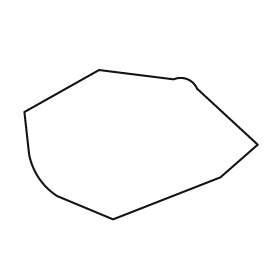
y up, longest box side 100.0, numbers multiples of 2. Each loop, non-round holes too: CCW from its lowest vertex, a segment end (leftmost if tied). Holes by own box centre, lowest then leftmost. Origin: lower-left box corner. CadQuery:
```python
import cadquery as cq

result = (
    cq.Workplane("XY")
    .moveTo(38.0, 0.0)
    .lineTo(84.0, 18.0)
    .lineTo(100.0, 32.0)
    .lineTo(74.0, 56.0)
    .threePointArc((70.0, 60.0), (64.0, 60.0))
    .lineTo(32.0, 64.0)
    .lineTo(0.0, 46.0)
    .lineTo(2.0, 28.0)
    .threePointArc((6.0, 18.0), (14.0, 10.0))
    .close()
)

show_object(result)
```